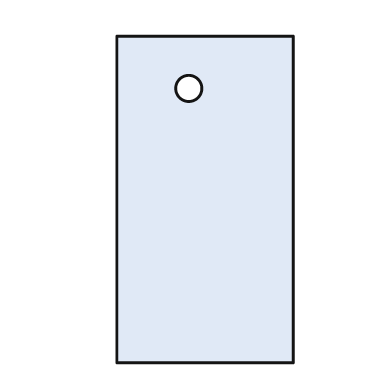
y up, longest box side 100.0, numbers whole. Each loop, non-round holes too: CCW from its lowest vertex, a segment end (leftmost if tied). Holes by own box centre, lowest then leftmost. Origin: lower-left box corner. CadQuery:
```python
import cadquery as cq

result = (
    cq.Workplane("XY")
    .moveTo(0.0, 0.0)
    .lineTo(54.0, 0.0)
    .lineTo(54.0, 100.0)
    .lineTo(0.0, 100.0)
    .close()
    .moveTo(22.0, 84.0)
    .circle(4.0)
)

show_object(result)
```